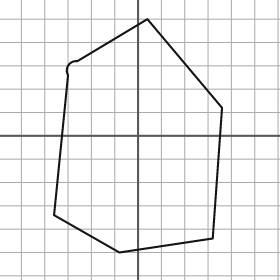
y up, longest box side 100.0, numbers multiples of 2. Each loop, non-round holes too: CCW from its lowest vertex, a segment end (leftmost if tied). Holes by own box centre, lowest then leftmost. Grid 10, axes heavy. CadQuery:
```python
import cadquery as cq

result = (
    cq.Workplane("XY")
    .moveTo(-8.0, -50.0)
    .lineTo(32.0, -44.0)
    .lineTo(36.0, 12.0)
    .lineTo(4.0, 50.0)
    .lineTo(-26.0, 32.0)
    .threePointArc((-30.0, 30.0), (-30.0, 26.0))
    .lineTo(-36.0, -34.0)
    .close()
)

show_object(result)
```